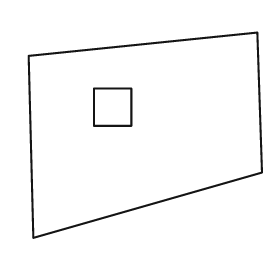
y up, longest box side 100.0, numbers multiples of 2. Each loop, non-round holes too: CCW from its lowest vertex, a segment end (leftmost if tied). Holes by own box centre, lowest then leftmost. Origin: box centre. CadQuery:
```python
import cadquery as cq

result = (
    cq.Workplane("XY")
    .moveTo(-48.0, -44.0)
    .lineTo(50.0, -16.0)
    .lineTo(48.0, 44.0)
    .lineTo(-50.0, 34.0)
    .close()
    .moveTo(-22.0, 4.0)
    .lineTo(-6.0, 4.0)
    .lineTo(-6.0, 20.0)
    .lineTo(-22.0, 20.0)
    .close()
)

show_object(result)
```